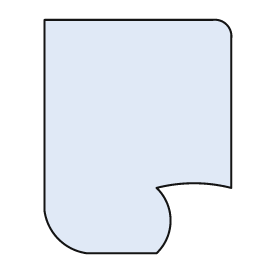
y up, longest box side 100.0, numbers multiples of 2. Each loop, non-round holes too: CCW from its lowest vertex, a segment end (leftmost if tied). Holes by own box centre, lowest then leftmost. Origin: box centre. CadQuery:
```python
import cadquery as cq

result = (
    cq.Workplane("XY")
    .moveTo(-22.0, -50.0)
    .lineTo(8.0, -50.0)
    .threePointArc((14.0, -36.0), (8.0, -22.0))
    .threePointArc((24.0, -20.0), (40.0, -22.0))
    .lineTo(40.0, 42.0)
    .threePointArc((38.0, 48.0), (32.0, 50.0))
    .lineTo(-40.0, 50.0)
    .lineTo(-40.0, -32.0)
    .threePointArc((-34.0, -44.0), (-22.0, -50.0))
    .close()
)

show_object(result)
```